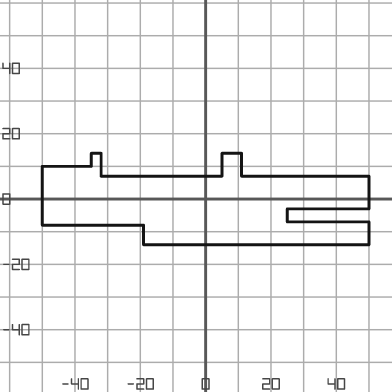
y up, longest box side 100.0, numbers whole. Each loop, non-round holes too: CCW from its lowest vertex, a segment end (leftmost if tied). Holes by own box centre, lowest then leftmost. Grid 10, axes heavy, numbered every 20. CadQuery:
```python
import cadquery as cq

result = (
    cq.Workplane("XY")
    .moveTo(-19.0, -14.0)
    .lineTo(50.0, -14.0)
    .lineTo(50.0, -7.0)
    .lineTo(25.0, -7.0)
    .lineTo(25.0, -3.0)
    .lineTo(50.0, -3.0)
    .lineTo(50.0, 7.0)
    .lineTo(11.0, 7.0)
    .lineTo(11.0, 14.0)
    .lineTo(5.0, 14.0)
    .lineTo(5.0, 7.0)
    .lineTo(-32.0, 7.0)
    .lineTo(-32.0, 14.0)
    .lineTo(-35.0, 14.0)
    .lineTo(-35.0, 10.0)
    .lineTo(-50.0, 10.0)
    .lineTo(-50.0, -8.0)
    .lineTo(-19.0, -8.0)
    .close()
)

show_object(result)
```